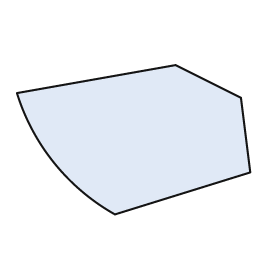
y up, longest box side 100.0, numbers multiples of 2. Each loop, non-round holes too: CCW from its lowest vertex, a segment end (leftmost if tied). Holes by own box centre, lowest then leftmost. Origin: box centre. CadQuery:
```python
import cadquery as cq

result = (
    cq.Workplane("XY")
    .moveTo(-8.0, -32.0)
    .lineTo(50.0, -14.0)
    .lineTo(46.0, 18.0)
    .lineTo(18.0, 32.0)
    .lineTo(-50.0, 20.0)
    .threePointArc((-34.0, -10.0), (-8.0, -32.0))
    .close()
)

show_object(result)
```